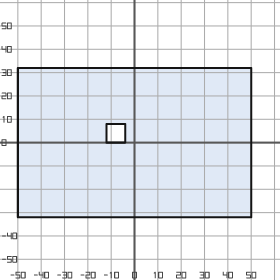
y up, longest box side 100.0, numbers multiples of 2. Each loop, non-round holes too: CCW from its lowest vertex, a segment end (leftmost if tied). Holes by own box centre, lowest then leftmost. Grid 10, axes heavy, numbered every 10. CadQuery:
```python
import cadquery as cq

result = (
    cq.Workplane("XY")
    .moveTo(-50.0, -32.0)
    .lineTo(50.0, -32.0)
    .lineTo(50.0, 32.0)
    .lineTo(-50.0, 32.0)
    .close()
    .moveTo(-12.0, 0.0)
    .lineTo(-4.0, 0.0)
    .lineTo(-4.0, 8.0)
    .lineTo(-12.0, 8.0)
    .close()
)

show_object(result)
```